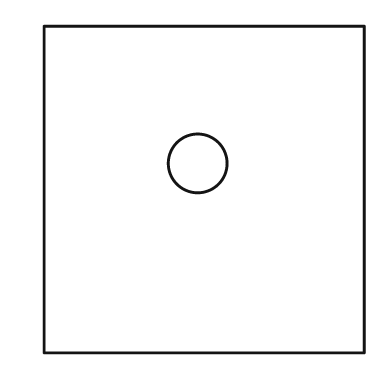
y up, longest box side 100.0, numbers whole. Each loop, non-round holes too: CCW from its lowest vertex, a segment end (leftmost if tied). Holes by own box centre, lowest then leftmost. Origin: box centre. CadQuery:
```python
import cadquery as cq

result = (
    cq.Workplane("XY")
    .moveTo(-49.0, -50.0)
    .lineTo(49.0, -50.0)
    .lineTo(49.0, 50.0)
    .lineTo(-49.0, 50.0)
    .close()
    .moveTo(-2.0, 8.0)
    .circle(9.0)
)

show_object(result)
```